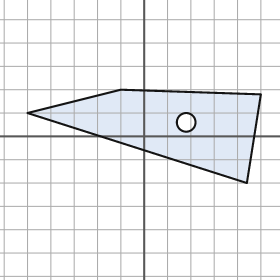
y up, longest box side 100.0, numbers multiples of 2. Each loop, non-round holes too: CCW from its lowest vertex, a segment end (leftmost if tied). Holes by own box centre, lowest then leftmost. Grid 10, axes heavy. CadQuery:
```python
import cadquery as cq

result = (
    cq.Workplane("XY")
    .moveTo(44.0, -20.0)
    .lineTo(50.0, 18.0)
    .lineTo(-10.0, 20.0)
    .lineTo(-50.0, 10.0)
    .close()
    .moveTo(18.0, 6.0)
    .circle(4.0)
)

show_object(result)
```